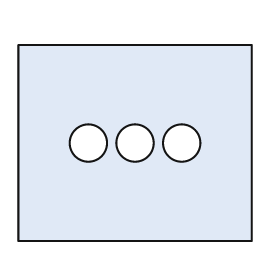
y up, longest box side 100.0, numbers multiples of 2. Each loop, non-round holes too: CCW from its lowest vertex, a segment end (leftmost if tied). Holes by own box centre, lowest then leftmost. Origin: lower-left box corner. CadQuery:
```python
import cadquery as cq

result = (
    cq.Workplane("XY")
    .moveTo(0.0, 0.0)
    .lineTo(100.0, 0.0)
    .lineTo(100.0, 84.0)
    .lineTo(0.0, 84.0)
    .close()
    .moveTo(30.0, 42.0)
    .circle(8.0)
    .moveTo(50.0, 42.0)
    .circle(8.0)
    .moveTo(70.0, 42.0)
    .circle(8.0)
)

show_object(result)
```